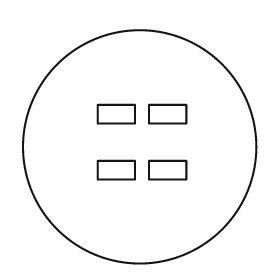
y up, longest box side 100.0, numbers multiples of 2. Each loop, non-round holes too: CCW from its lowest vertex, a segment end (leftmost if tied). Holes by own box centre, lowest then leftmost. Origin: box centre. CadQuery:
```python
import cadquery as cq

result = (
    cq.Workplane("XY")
    .moveTo(0.0, 0.0)
    .circle(50.0)
    .moveTo(-18.0, -14.0)
    .lineTo(-2.0, -14.0)
    .lineTo(-2.0, -6.0)
    .lineTo(-18.0, -6.0)
    .close()
    .moveTo(4.0, -14.0)
    .lineTo(20.0, -14.0)
    .lineTo(20.0, -6.0)
    .lineTo(4.0, -6.0)
    .close()
    .moveTo(-18.0, 10.0)
    .lineTo(-2.0, 10.0)
    .lineTo(-2.0, 18.0)
    .lineTo(-18.0, 18.0)
    .close()
    .moveTo(4.0, 10.0)
    .lineTo(20.0, 10.0)
    .lineTo(20.0, 18.0)
    .lineTo(4.0, 18.0)
    .close()
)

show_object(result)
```